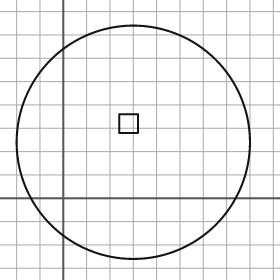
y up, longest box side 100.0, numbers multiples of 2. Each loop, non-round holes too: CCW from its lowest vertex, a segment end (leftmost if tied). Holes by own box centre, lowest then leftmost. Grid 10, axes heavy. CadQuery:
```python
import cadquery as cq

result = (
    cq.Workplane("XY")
    .moveTo(30.0, 24.0)
    .circle(50.0)
    .moveTo(24.0, 28.0)
    .lineTo(32.0, 28.0)
    .lineTo(32.0, 36.0)
    .lineTo(24.0, 36.0)
    .close()
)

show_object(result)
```